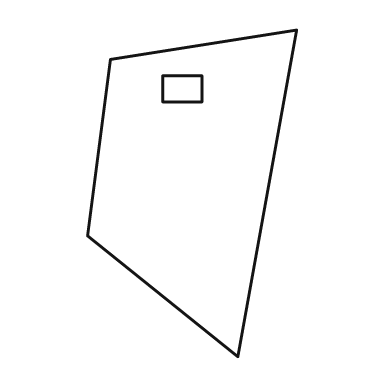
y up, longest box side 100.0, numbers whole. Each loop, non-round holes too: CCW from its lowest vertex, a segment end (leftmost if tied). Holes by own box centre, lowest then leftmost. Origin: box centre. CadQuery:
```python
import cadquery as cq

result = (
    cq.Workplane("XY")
    .moveTo(14.0, -50.0)
    .lineTo(32.0, 50.0)
    .lineTo(-25.0, 41.0)
    .lineTo(-32.0, -13.0)
    .close()
    .moveTo(-9.0, 28.0)
    .lineTo(3.0, 28.0)
    .lineTo(3.0, 36.0)
    .lineTo(-9.0, 36.0)
    .close()
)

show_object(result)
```